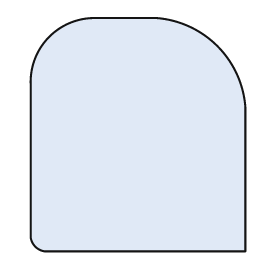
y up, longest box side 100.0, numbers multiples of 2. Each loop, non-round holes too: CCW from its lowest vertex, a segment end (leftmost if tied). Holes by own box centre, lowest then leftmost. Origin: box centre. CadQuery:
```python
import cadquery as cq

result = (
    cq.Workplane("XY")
    .moveTo(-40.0, -50.0)
    .lineTo(46.0, -50.0)
    .lineTo(46.0, 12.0)
    .threePointArc((34.0, 38.0), (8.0, 50.0))
    .lineTo(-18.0, 50.0)
    .threePointArc((-38.0, 42.0), (-46.0, 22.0))
    .lineTo(-46.0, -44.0)
    .threePointArc((-44.0, -48.0), (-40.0, -50.0))
    .close()
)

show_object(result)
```